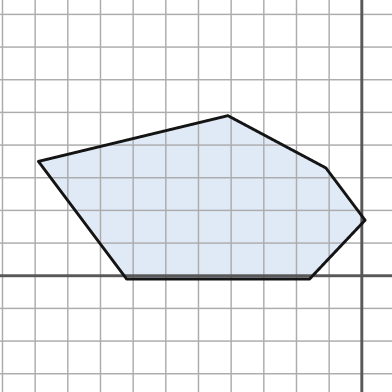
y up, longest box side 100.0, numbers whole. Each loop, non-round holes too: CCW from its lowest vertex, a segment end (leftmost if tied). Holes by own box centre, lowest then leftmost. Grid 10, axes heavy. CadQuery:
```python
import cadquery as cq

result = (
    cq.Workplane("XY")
    .moveTo(-72.0, -1.0)
    .lineTo(-16.0, -1.0)
    .lineTo(1.0, 17.0)
    .lineTo(-11.0, 33.0)
    .lineTo(-41.0, 49.0)
    .lineTo(-99.0, 35.0)
    .close()
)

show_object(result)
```